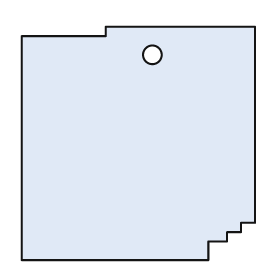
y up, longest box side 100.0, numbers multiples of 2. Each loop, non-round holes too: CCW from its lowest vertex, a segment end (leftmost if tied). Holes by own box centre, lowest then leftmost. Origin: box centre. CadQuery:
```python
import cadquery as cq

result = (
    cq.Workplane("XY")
    .moveTo(-50.0, -50.0)
    .lineTo(30.0, -50.0)
    .lineTo(30.0, -42.0)
    .lineTo(38.0, -42.0)
    .lineTo(38.0, -38.0)
    .lineTo(44.0, -38.0)
    .lineTo(44.0, -34.0)
    .lineTo(50.0, -34.0)
    .lineTo(50.0, 50.0)
    .lineTo(-14.0, 50.0)
    .lineTo(-14.0, 46.0)
    .lineTo(-50.0, 46.0)
    .close()
    .moveTo(6.0, 38.0)
    .circle(4.0)
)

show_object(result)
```